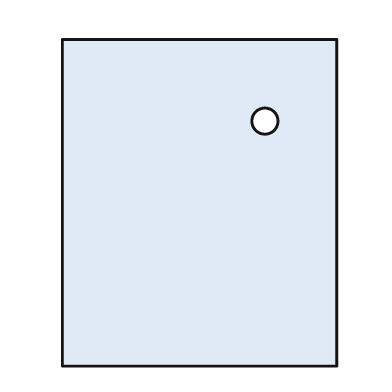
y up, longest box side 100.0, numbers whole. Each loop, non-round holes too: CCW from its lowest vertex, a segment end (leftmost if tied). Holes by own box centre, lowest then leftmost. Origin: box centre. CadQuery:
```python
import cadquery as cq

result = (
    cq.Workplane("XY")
    .moveTo(-42.0, -50.0)
    .lineTo(42.0, -50.0)
    .lineTo(42.0, 50.0)
    .lineTo(-42.0, 50.0)
    .close()
    .moveTo(20.0, 25.0)
    .circle(4.0)
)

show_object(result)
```